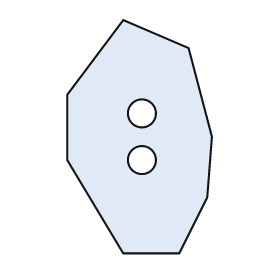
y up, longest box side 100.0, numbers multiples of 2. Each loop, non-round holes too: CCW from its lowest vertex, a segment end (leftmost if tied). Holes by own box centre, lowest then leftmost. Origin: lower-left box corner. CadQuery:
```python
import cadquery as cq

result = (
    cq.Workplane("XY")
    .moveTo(24.0, 0.0)
    .lineTo(48.0, 0.0)
    .lineTo(60.0, 24.0)
    .lineTo(62.0, 50.0)
    .lineTo(52.0, 88.0)
    .lineTo(24.0, 100.0)
    .lineTo(0.0, 68.0)
    .lineTo(0.0, 40.0)
    .close()
    .moveTo(32.0, 40.0)
    .circle(6.0)
    .moveTo(32.0, 60.0)
    .circle(6.0)
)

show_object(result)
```